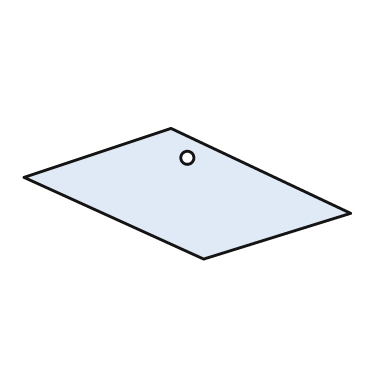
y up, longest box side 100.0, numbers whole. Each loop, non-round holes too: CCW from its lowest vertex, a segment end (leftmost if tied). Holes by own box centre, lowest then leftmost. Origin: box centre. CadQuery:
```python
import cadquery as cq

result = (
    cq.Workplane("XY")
    .moveTo(5.0, -20.0)
    .lineTo(50.0, -6.0)
    .lineTo(-5.0, 20.0)
    .lineTo(-50.0, 5.0)
    .close()
    .moveTo(0.0, 11.0)
    .circle(2.0)
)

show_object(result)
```